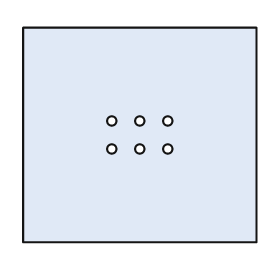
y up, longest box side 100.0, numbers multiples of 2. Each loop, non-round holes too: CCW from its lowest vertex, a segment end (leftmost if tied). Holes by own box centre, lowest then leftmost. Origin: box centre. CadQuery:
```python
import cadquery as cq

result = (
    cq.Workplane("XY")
    .moveTo(-50.0, -46.0)
    .lineTo(50.0, -46.0)
    .lineTo(50.0, 46.0)
    .lineTo(-50.0, 46.0)
    .close()
    .moveTo(-12.0, -6.0)
    .circle(2.0)
    .moveTo(0.0, -6.0)
    .circle(2.0)
    .moveTo(12.0, -6.0)
    .circle(2.0)
    .moveTo(-12.0, 6.0)
    .circle(2.0)
    .moveTo(0.0, 6.0)
    .circle(2.0)
    .moveTo(12.0, 6.0)
    .circle(2.0)
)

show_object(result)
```